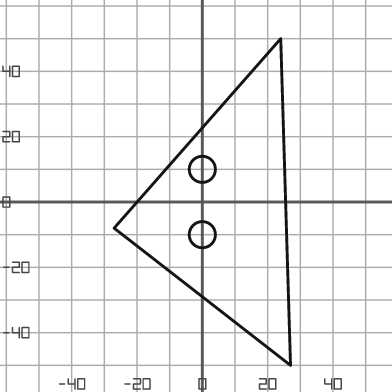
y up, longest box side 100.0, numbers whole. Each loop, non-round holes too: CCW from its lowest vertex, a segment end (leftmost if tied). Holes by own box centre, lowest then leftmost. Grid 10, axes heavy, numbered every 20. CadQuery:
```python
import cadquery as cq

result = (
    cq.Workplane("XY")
    .moveTo(27.0, -50.0)
    .lineTo(24.0, 50.0)
    .lineTo(-27.0, -8.0)
    .close()
    .moveTo(0.0, -10.0)
    .circle(4.0)
    .moveTo(0.0, 10.0)
    .circle(4.0)
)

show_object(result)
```